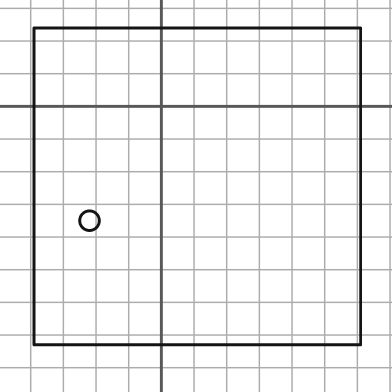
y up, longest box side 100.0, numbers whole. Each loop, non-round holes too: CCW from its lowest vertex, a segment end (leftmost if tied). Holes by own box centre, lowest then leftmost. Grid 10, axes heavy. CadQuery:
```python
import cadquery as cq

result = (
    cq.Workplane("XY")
    .moveTo(-39.0, -73.0)
    .lineTo(61.0, -73.0)
    .lineTo(61.0, 24.0)
    .lineTo(-39.0, 24.0)
    .close()
    .moveTo(-22.0, -35.0)
    .circle(3.0)
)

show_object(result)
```